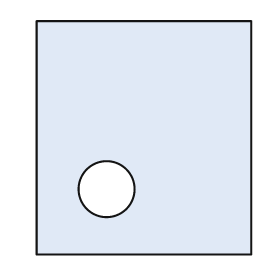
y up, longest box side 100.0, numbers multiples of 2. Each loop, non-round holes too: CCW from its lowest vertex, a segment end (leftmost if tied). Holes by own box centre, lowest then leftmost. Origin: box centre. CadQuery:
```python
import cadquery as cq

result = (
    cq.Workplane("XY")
    .moveTo(-46.0, -50.0)
    .lineTo(46.0, -50.0)
    .lineTo(46.0, 50.0)
    .lineTo(-46.0, 50.0)
    .close()
    .moveTo(-16.0, -22.0)
    .circle(12.0)
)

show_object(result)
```